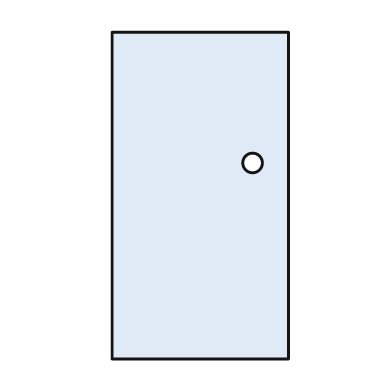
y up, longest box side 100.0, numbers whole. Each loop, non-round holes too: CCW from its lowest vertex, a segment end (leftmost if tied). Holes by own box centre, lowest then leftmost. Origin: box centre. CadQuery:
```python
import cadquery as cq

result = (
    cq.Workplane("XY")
    .moveTo(-27.0, -50.0)
    .lineTo(27.0, -50.0)
    .lineTo(27.0, 50.0)
    .lineTo(-27.0, 50.0)
    .close()
    .moveTo(16.0, 10.0)
    .circle(3.0)
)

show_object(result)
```